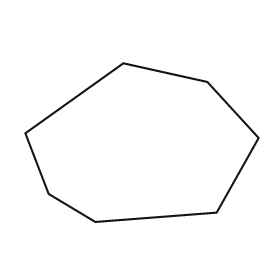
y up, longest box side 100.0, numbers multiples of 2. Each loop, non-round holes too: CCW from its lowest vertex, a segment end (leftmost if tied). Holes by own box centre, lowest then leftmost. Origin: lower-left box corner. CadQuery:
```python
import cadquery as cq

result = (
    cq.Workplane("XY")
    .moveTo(30.0, 0.0)
    .lineTo(82.0, 4.0)
    .lineTo(100.0, 36.0)
    .lineTo(78.0, 60.0)
    .lineTo(42.0, 68.0)
    .lineTo(0.0, 38.0)
    .lineTo(10.0, 12.0)
    .close()
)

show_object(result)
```